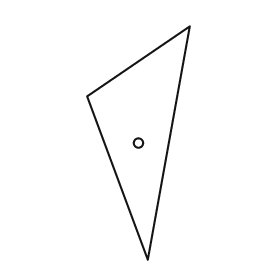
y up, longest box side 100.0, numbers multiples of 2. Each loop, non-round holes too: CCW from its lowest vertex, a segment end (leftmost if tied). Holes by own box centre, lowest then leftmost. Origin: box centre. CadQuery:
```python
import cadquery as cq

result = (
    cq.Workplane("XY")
    .moveTo(4.0, -50.0)
    .lineTo(22.0, 50.0)
    .lineTo(-22.0, 20.0)
    .close()
    .moveTo(0.0, 0.0)
    .circle(2.0)
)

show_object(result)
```